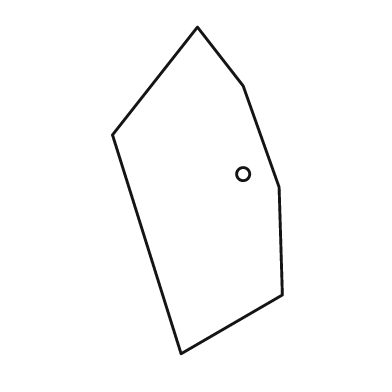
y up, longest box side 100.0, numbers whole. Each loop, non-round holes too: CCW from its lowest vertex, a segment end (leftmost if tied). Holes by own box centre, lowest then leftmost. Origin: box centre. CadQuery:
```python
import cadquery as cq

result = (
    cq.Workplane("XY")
    .moveTo(-5.0, -50.0)
    .lineTo(26.0, -32.0)
    .lineTo(25.0, 1.0)
    .lineTo(14.0, 32.0)
    .lineTo(0.0, 50.0)
    .lineTo(-26.0, 17.0)
    .close()
    .moveTo(14.0, 5.0)
    .circle(2.0)
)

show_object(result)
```